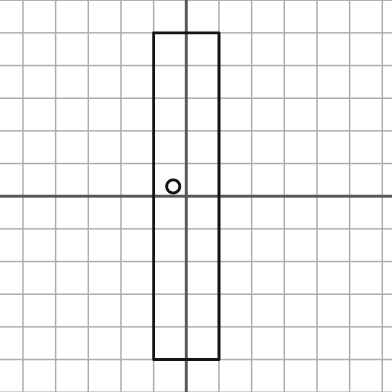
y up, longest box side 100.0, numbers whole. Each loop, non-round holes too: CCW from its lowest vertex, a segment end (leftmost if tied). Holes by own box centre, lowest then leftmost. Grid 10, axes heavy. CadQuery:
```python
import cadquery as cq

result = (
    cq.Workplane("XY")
    .moveTo(-10.0, -50.0)
    .lineTo(10.0, -50.0)
    .lineTo(10.0, 50.0)
    .lineTo(-10.0, 50.0)
    .close()
    .moveTo(-4.0, 3.0)
    .circle(2.0)
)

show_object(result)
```